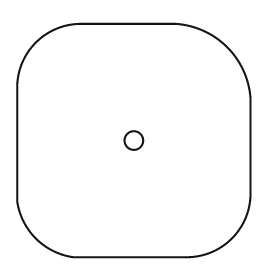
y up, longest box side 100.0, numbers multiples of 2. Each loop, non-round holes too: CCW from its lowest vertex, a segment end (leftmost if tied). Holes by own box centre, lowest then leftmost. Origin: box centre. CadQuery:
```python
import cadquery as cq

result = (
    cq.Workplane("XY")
    .moveTo(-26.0, -50.0)
    .lineTo(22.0, -50.0)
    .threePointArc((42.0, -42.0), (50.0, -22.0))
    .lineTo(50.0, 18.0)
    .threePointArc((40.0, 40.0), (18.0, 50.0))
    .lineTo(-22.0, 50.0)
    .threePointArc((-42.0, 42.0), (-50.0, 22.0))
    .lineTo(-50.0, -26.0)
    .threePointArc((-42.0, -42.0), (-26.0, -50.0))
    .close()
    .moveTo(0.0, 0.0)
    .circle(4.0)
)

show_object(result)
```